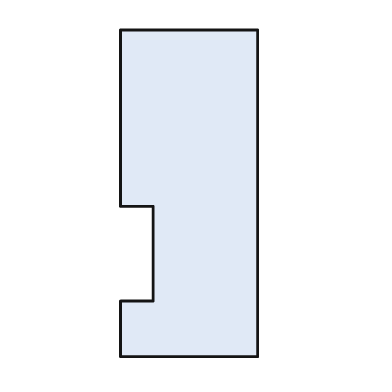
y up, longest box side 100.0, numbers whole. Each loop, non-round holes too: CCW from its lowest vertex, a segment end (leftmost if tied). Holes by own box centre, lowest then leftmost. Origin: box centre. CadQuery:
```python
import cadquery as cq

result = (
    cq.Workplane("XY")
    .moveTo(-21.0, -50.0)
    .lineTo(21.0, -50.0)
    .lineTo(21.0, 50.0)
    .lineTo(-21.0, 50.0)
    .lineTo(-21.0, -4.0)
    .lineTo(-11.0, -4.0)
    .lineTo(-11.0, -33.0)
    .lineTo(-21.0, -33.0)
    .close()
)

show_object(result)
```